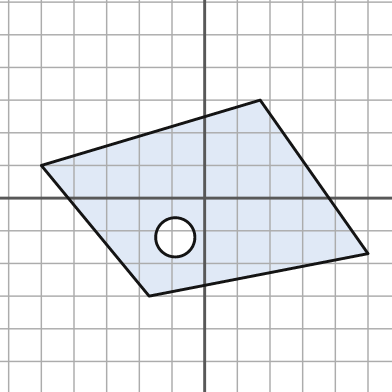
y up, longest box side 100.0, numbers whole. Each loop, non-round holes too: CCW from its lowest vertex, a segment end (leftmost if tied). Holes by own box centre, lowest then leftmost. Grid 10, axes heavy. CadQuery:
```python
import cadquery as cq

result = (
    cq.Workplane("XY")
    .moveTo(-17.0, -30.0)
    .lineTo(50.0, -17.0)
    .lineTo(17.0, 30.0)
    .lineTo(-50.0, 10.0)
    .close()
    .moveTo(-9.0, -12.0)
    .circle(6.0)
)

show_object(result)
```